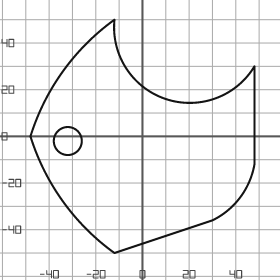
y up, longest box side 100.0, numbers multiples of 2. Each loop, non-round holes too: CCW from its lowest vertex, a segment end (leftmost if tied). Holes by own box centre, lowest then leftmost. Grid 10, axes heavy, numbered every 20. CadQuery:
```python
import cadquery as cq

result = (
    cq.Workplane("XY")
    .moveTo(-12.0, -50.0)
    .lineTo(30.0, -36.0)
    .threePointArc((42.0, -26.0), (48.0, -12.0))
    .lineTo(48.0, 30.0)
    .threePointArc((10.0, 16.0), (-12.0, 50.0))
    .threePointArc((-34.0, 28.0), (-48.0, 0.0))
    .threePointArc((-34.0, -28.0), (-12.0, -50.0))
    .close()
    .moveTo(-32.0, -2.0)
    .circle(6.0)
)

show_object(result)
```